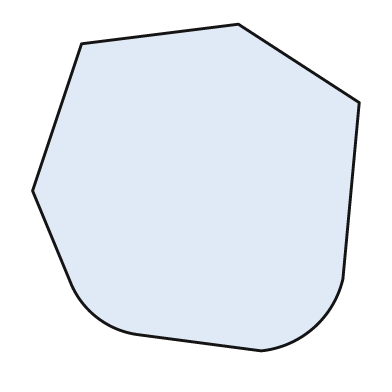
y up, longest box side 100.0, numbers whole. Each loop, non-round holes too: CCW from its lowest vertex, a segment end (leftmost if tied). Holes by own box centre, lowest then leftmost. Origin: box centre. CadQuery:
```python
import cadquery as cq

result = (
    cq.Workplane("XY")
    .moveTo(20.0, -50.0)
    .threePointArc((36.0, -43.0), (45.0, -28.0))
    .lineTo(50.0, 26.0)
    .lineTo(13.0, 50.0)
    .lineTo(-35.0, 44.0)
    .lineTo(-50.0, -1.0)
    .lineTo(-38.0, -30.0)
    .threePointArc((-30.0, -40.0), (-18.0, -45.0))
    .close()
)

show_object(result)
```